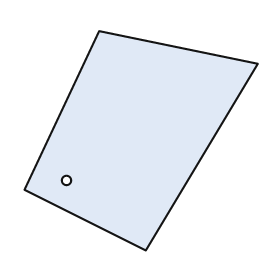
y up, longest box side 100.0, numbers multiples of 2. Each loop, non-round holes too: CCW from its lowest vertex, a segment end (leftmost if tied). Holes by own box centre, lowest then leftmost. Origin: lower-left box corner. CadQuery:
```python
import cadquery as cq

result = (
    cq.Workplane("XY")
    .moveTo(52.0, 0.0)
    .lineTo(100.0, 80.0)
    .lineTo(32.0, 94.0)
    .lineTo(0.0, 26.0)
    .close()
    .moveTo(18.0, 30.0)
    .circle(2.0)
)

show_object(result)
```